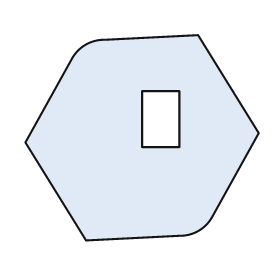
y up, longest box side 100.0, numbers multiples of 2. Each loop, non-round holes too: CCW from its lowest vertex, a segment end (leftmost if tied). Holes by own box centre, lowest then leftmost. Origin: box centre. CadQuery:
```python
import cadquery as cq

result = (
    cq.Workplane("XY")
    .moveTo(-24.0, -44.0)
    .lineTo(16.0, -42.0)
    .threePointArc((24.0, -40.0), (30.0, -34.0))
    .lineTo(50.0, 2.0)
    .lineTo(24.0, 44.0)
    .lineTo(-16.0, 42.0)
    .threePointArc((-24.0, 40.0), (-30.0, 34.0))
    .lineTo(-50.0, -2.0)
    .close()
    .moveTo(0.0, -4.0)
    .lineTo(16.0, -4.0)
    .lineTo(16.0, 20.0)
    .lineTo(0.0, 20.0)
    .close()
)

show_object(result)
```